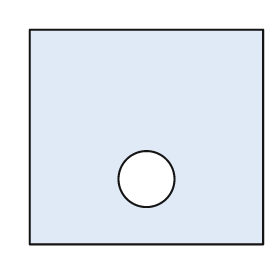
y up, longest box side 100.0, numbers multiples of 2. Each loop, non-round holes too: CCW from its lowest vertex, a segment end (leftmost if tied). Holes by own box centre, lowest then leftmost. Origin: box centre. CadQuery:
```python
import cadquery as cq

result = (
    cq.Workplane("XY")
    .moveTo(-50.0, -46.0)
    .lineTo(50.0, -46.0)
    .lineTo(50.0, 46.0)
    .lineTo(-50.0, 46.0)
    .close()
    .moveTo(0.0, -18.0)
    .circle(12.0)
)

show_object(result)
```